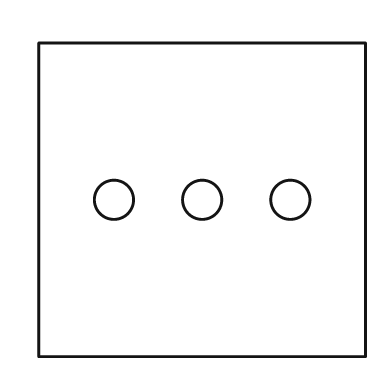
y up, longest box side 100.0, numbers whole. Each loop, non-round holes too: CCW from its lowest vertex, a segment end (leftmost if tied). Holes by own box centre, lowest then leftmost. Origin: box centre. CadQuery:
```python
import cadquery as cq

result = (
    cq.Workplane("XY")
    .moveTo(-50.0, -48.0)
    .lineTo(50.0, -48.0)
    .lineTo(50.0, 48.0)
    .lineTo(-50.0, 48.0)
    .close()
    .moveTo(-27.0, 0.0)
    .circle(6.0)
    .moveTo(0.0, 0.0)
    .circle(6.0)
    .moveTo(27.0, 0.0)
    .circle(6.0)
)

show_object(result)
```